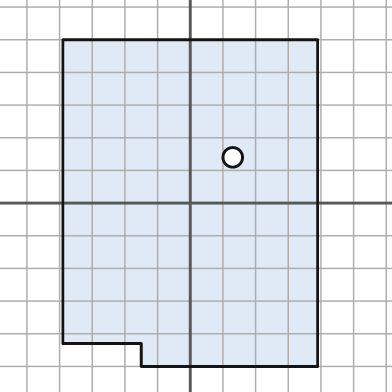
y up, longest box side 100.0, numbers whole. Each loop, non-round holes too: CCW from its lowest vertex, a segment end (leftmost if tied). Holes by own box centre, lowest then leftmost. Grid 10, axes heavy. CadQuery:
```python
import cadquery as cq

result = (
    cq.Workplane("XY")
    .moveTo(-15.0, -50.0)
    .lineTo(39.0, -50.0)
    .lineTo(39.0, 50.0)
    .lineTo(-39.0, 50.0)
    .lineTo(-39.0, -43.0)
    .lineTo(-15.0, -43.0)
    .close()
    .moveTo(13.0, 14.0)
    .circle(3.0)
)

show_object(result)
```